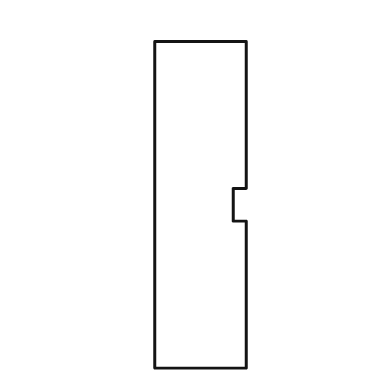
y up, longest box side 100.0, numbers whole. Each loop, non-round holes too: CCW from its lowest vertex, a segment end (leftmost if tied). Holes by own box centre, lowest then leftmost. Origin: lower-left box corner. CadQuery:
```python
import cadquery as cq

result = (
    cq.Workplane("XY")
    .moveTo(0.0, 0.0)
    .lineTo(28.0, 0.0)
    .lineTo(28.0, 45.0)
    .lineTo(24.0, 45.0)
    .lineTo(24.0, 55.0)
    .lineTo(28.0, 55.0)
    .lineTo(28.0, 100.0)
    .lineTo(0.0, 100.0)
    .close()
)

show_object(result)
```